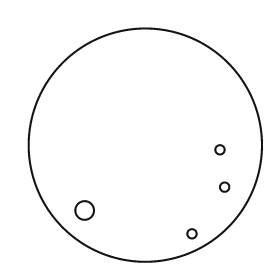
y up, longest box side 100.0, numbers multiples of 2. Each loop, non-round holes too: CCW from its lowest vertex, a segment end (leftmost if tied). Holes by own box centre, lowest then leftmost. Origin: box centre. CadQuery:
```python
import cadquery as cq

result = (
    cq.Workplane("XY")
    .moveTo(0.0, 0.0)
    .circle(50.0)
    .moveTo(20.0, -38.0)
    .circle(2.0)
    .moveTo(-26.0, -28.0)
    .circle(4.0)
    .moveTo(34.0, -18.0)
    .circle(2.0)
    .moveTo(32.0, -2.0)
    .circle(2.0)
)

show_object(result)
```